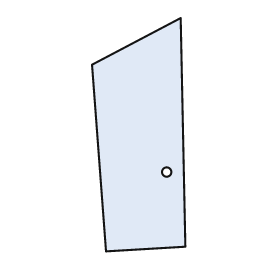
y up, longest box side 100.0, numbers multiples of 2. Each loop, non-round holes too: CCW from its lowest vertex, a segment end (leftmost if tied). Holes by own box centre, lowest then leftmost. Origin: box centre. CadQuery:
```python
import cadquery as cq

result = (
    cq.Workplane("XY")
    .moveTo(-14.0, -50.0)
    .lineTo(20.0, -48.0)
    .lineTo(18.0, 50.0)
    .lineTo(-20.0, 30.0)
    .close()
    .moveTo(12.0, -16.0)
    .circle(2.0)
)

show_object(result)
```